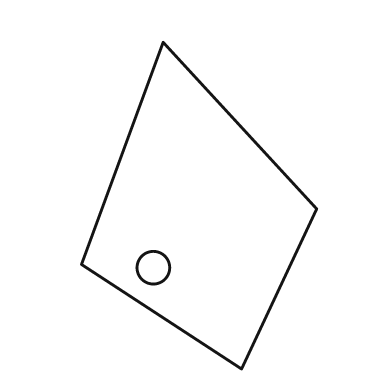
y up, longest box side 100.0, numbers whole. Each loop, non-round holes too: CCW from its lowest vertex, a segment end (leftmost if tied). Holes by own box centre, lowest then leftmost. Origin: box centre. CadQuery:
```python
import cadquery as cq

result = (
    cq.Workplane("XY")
    .moveTo(13.0, -50.0)
    .lineTo(36.0, -1.0)
    .lineTo(-11.0, 50.0)
    .lineTo(-36.0, -18.0)
    .close()
    .moveTo(-14.0, -19.0)
    .circle(5.0)
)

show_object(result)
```